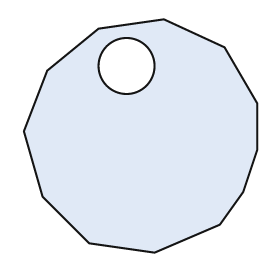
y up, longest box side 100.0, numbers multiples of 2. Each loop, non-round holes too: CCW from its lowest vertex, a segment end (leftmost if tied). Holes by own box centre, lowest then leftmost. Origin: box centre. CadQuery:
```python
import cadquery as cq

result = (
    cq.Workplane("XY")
    .moveTo(6.0, -50.0)
    .lineTo(34.0, -38.0)
    .lineTo(44.0, -24.0)
    .lineTo(50.0, -6.0)
    .lineTo(50.0, 14.0)
    .lineTo(36.0, 38.0)
    .lineTo(10.0, 50.0)
    .lineTo(-18.0, 46.0)
    .lineTo(-40.0, 28.0)
    .lineTo(-50.0, 2.0)
    .lineTo(-42.0, -26.0)
    .lineTo(-22.0, -46.0)
    .close()
    .moveTo(-6.0, 30.0)
    .circle(12.0)
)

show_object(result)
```